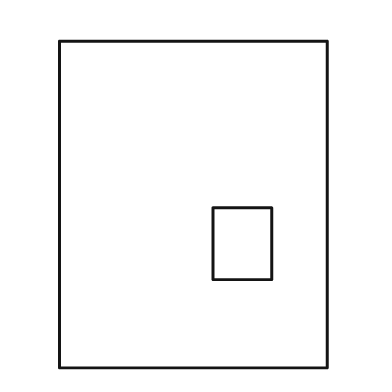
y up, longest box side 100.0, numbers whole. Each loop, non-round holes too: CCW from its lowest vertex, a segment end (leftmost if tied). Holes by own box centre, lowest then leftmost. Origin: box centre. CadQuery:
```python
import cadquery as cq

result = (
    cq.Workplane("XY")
    .moveTo(-41.0, -50.0)
    .lineTo(41.0, -50.0)
    .lineTo(41.0, 50.0)
    .lineTo(-41.0, 50.0)
    .close()
    .moveTo(6.0, -23.0)
    .lineTo(24.0, -23.0)
    .lineTo(24.0, -1.0)
    .lineTo(6.0, -1.0)
    .close()
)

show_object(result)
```